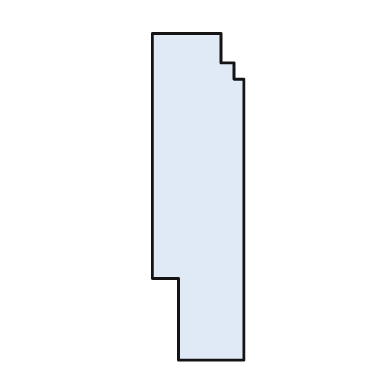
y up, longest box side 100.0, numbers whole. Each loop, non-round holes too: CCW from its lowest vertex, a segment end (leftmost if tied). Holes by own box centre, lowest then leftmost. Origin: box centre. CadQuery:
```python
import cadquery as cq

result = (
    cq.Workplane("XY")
    .moveTo(-6.0, -50.0)
    .lineTo(14.0, -50.0)
    .lineTo(14.0, 36.0)
    .lineTo(11.0, 36.0)
    .lineTo(11.0, 41.0)
    .lineTo(7.0, 41.0)
    .lineTo(7.0, 50.0)
    .lineTo(-14.0, 50.0)
    .lineTo(-14.0, -25.0)
    .lineTo(-6.0, -25.0)
    .close()
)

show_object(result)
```